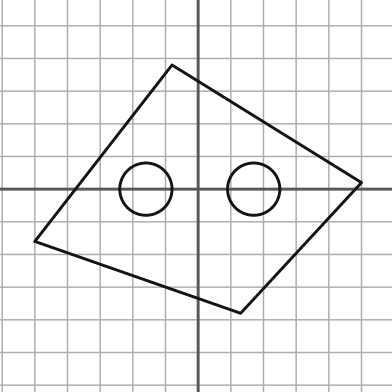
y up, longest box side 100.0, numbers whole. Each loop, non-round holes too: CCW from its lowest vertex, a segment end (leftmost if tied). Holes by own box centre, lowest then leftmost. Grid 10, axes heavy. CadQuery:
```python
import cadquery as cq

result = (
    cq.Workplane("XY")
    .moveTo(13.0, -38.0)
    .lineTo(50.0, 2.0)
    .lineTo(-8.0, 38.0)
    .lineTo(-50.0, -16.0)
    .close()
    .moveTo(-16.0, 0.0)
    .circle(8.0)
    .moveTo(17.0, 0.0)
    .circle(8.0)
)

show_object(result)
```